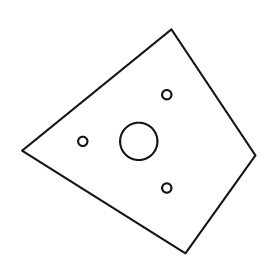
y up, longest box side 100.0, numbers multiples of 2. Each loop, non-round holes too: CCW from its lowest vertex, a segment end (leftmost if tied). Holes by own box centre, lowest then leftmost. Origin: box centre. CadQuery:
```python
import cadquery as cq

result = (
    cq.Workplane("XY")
    .moveTo(20.0, -48.0)
    .lineTo(50.0, -6.0)
    .lineTo(14.0, 48.0)
    .lineTo(-50.0, -4.0)
    .close()
    .moveTo(12.0, -20.0)
    .circle(2.0)
    .moveTo(-24.0, 0.0)
    .circle(2.0)
    .moveTo(0.0, 0.0)
    .circle(8.0)
    .moveTo(12.0, 20.0)
    .circle(2.0)
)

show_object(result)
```